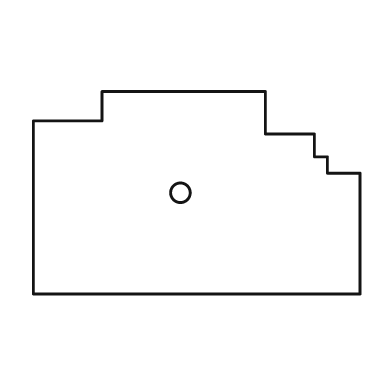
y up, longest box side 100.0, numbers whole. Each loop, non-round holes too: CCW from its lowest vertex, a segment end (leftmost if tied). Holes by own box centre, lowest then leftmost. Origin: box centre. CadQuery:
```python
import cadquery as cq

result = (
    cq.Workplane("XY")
    .moveTo(-50.0, -31.0)
    .lineTo(50.0, -31.0)
    .lineTo(50.0, 6.0)
    .lineTo(40.0, 6.0)
    .lineTo(40.0, 11.0)
    .lineTo(36.0, 11.0)
    .lineTo(36.0, 18.0)
    .lineTo(21.0, 18.0)
    .lineTo(21.0, 31.0)
    .lineTo(-29.0, 31.0)
    .lineTo(-29.0, 22.0)
    .lineTo(-50.0, 22.0)
    .close()
    .moveTo(-5.0, 0.0)
    .circle(3.0)
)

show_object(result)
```